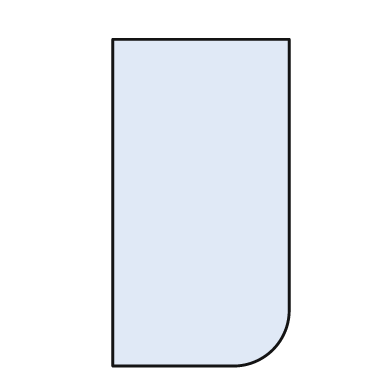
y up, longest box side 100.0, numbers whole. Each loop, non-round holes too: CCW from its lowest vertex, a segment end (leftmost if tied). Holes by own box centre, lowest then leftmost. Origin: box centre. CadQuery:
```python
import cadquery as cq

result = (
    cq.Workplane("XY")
    .moveTo(-27.0, -50.0)
    .lineTo(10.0, -50.0)
    .threePointArc((22.0, -45.0), (27.0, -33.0))
    .lineTo(27.0, 50.0)
    .lineTo(-27.0, 50.0)
    .close()
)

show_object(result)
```